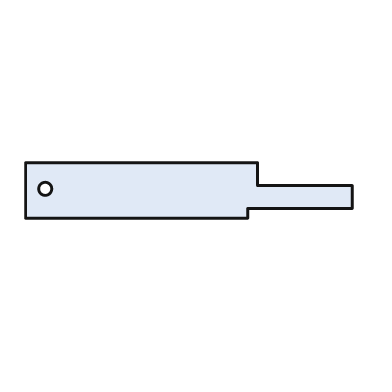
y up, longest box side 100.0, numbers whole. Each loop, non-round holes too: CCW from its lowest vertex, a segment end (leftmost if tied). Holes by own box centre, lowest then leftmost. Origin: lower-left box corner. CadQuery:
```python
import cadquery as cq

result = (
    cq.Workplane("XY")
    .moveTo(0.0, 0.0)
    .lineTo(68.0, 0.0)
    .lineTo(68.0, 3.0)
    .lineTo(100.0, 3.0)
    .lineTo(100.0, 10.0)
    .lineTo(71.0, 10.0)
    .lineTo(71.0, 17.0)
    .lineTo(0.0, 17.0)
    .close()
    .moveTo(6.0, 9.0)
    .circle(2.0)
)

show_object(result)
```